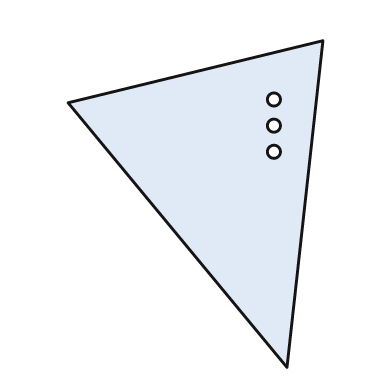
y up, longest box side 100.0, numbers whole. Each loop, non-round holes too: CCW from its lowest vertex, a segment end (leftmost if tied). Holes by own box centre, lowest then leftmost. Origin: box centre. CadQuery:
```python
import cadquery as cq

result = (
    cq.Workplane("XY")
    .moveTo(28.0, -50.0)
    .lineTo(39.0, 50.0)
    .lineTo(-39.0, 31.0)
    .close()
    .moveTo(24.0, 16.0)
    .circle(2.0)
    .moveTo(24.0, 24.0)
    .circle(2.0)
    .moveTo(24.0, 32.0)
    .circle(2.0)
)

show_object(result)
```